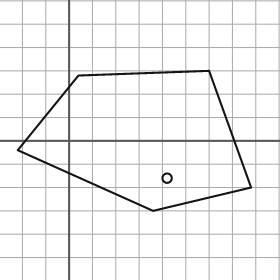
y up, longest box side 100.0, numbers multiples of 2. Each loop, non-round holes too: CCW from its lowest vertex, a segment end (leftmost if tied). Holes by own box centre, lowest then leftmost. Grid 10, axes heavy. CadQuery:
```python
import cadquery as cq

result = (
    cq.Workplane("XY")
    .moveTo(36.0, -30.0)
    .lineTo(78.0, -20.0)
    .lineTo(60.0, 30.0)
    .lineTo(4.0, 28.0)
    .lineTo(-22.0, -4.0)
    .close()
    .moveTo(42.0, -16.0)
    .circle(2.0)
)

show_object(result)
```